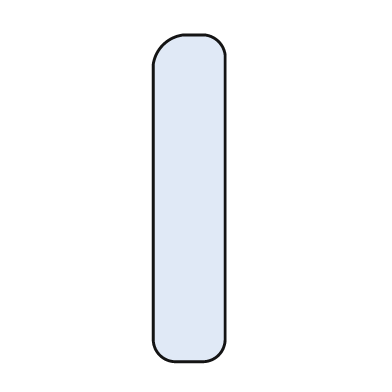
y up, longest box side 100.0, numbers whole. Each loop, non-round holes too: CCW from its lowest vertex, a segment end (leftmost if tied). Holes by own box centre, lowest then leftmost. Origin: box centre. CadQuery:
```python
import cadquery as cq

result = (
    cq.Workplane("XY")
    .moveTo(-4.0, -50.0)
    .lineTo(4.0, -50.0)
    .threePointArc((9.0, -48.0), (11.0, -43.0))
    .lineTo(11.0, 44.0)
    .threePointArc((9.0, 48.0), (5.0, 50.0))
    .lineTo(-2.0, 50.0)
    .threePointArc((-8.0, 47.0), (-11.0, 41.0))
    .lineTo(-11.0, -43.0)
    .threePointArc((-9.0, -48.0), (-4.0, -50.0))
    .close()
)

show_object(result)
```